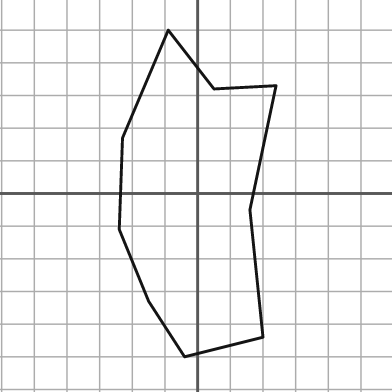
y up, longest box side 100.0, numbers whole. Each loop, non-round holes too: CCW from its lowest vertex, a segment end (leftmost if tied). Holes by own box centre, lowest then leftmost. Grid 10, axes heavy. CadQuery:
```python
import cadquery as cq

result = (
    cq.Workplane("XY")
    .moveTo(-4.0, -50.0)
    .lineTo(20.0, -44.0)
    .lineTo(16.0, -5.0)
    .lineTo(24.0, 33.0)
    .lineTo(5.0, 32.0)
    .lineTo(-9.0, 50.0)
    .lineTo(-23.0, 17.0)
    .lineTo(-24.0, -11.0)
    .lineTo(-15.0, -33.0)
    .close()
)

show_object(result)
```